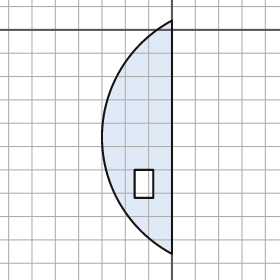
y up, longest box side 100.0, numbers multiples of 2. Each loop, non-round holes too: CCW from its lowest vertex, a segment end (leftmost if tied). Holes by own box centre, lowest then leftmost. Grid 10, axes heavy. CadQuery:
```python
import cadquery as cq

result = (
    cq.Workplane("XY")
    .moveTo(0.0, -96.0)
    .lineTo(0.0, 4.0)
    .threePointArc((-30.0, -46.0), (0.0, -96.0))
    .close()
    .moveTo(-16.0, -72.0)
    .lineTo(-8.0, -72.0)
    .lineTo(-8.0, -60.0)
    .lineTo(-16.0, -60.0)
    .close()
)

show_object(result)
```